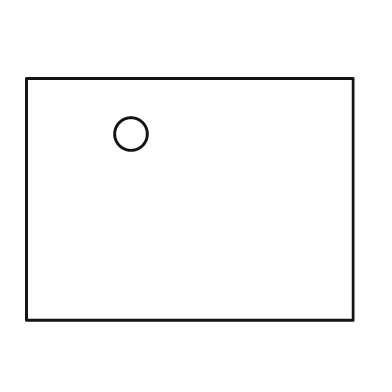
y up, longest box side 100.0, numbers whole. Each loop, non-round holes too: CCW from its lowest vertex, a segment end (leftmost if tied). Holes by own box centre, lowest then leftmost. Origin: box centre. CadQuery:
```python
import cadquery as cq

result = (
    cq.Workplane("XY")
    .moveTo(-50.0, -37.0)
    .lineTo(50.0, -37.0)
    .lineTo(50.0, 37.0)
    .lineTo(-50.0, 37.0)
    .close()
    .moveTo(-18.0, 20.0)
    .circle(5.0)
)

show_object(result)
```